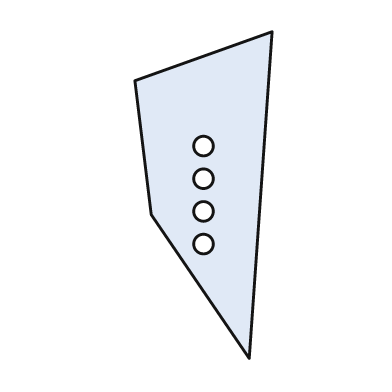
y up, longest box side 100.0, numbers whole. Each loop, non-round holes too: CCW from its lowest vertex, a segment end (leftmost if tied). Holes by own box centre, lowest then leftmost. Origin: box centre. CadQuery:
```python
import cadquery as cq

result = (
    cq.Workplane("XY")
    .moveTo(14.0, -50.0)
    .lineTo(21.0, 50.0)
    .lineTo(-21.0, 35.0)
    .lineTo(-16.0, -6.0)
    .close()
    .moveTo(0.0, -15.0)
    .circle(3.0)
    .moveTo(0.0, -5.0)
    .circle(3.0)
    .moveTo(0.0, 5.0)
    .circle(3.0)
    .moveTo(0.0, 15.0)
    .circle(3.0)
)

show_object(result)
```